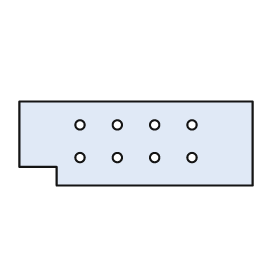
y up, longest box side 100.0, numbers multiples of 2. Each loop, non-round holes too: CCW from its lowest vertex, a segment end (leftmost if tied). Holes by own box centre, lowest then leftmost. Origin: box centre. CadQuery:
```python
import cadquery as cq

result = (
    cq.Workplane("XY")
    .moveTo(-34.0, -18.0)
    .lineTo(50.0, -18.0)
    .lineTo(50.0, 18.0)
    .lineTo(-50.0, 18.0)
    .lineTo(-50.0, -10.0)
    .lineTo(-34.0, -10.0)
    .close()
    .moveTo(-24.0, -6.0)
    .circle(2.0)
    .moveTo(-8.0, -6.0)
    .circle(2.0)
    .moveTo(8.0, -6.0)
    .circle(2.0)
    .moveTo(24.0, -6.0)
    .circle(2.0)
    .moveTo(-24.0, 8.0)
    .circle(2.0)
    .moveTo(-8.0, 8.0)
    .circle(2.0)
    .moveTo(8.0, 8.0)
    .circle(2.0)
    .moveTo(24.0, 8.0)
    .circle(2.0)
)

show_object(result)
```